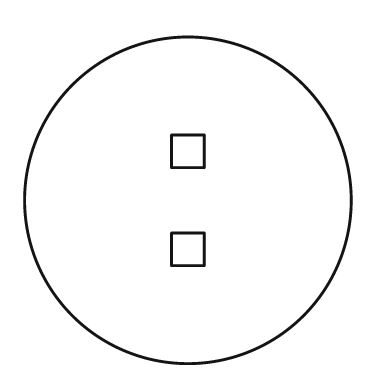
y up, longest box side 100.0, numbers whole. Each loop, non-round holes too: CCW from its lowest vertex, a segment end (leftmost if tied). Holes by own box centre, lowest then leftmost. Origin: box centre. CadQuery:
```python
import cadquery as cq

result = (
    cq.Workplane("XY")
    .moveTo(0.0, 0.0)
    .circle(50.0)
    .moveTo(-5.0, -20.0)
    .lineTo(5.0, -20.0)
    .lineTo(5.0, -10.0)
    .lineTo(-5.0, -10.0)
    .close()
    .moveTo(-5.0, 10.0)
    .lineTo(5.0, 10.0)
    .lineTo(5.0, 20.0)
    .lineTo(-5.0, 20.0)
    .close()
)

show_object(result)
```